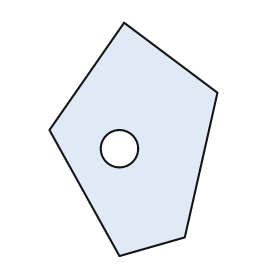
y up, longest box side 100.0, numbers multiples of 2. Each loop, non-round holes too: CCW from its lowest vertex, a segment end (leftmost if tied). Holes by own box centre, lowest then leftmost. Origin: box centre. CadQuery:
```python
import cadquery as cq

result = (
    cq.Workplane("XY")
    .moveTo(-6.0, -50.0)
    .lineTo(22.0, -42.0)
    .lineTo(36.0, 20.0)
    .lineTo(-4.0, 50.0)
    .lineTo(-36.0, 4.0)
    .close()
    .moveTo(-6.0, -4.0)
    .circle(8.0)
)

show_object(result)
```